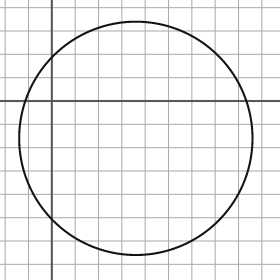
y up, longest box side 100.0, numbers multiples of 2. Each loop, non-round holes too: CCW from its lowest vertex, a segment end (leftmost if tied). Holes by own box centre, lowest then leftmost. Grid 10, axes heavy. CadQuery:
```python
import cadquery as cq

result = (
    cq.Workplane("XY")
    .moveTo(36.0, -16.0)
    .circle(50.0)
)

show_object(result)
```